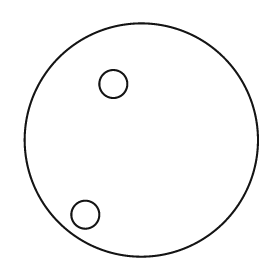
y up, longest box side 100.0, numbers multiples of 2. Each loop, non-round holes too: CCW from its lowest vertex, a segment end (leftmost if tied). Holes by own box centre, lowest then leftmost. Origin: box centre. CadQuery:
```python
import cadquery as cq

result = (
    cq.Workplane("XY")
    .moveTo(0.0, 0.0)
    .circle(50.0)
    .moveTo(-24.0, -32.0)
    .circle(6.0)
    .moveTo(-12.0, 24.0)
    .circle(6.0)
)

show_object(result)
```